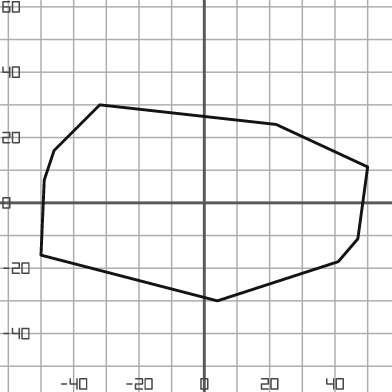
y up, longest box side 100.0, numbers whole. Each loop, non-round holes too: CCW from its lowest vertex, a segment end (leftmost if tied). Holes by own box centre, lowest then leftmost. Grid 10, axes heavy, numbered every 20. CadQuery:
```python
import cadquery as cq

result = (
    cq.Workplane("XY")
    .moveTo(4.0, -30.0)
    .lineTo(41.0, -18.0)
    .lineTo(47.0, -11.0)
    .lineTo(50.0, 11.0)
    .lineTo(22.0, 24.0)
    .lineTo(-32.0, 30.0)
    .lineTo(-46.0, 16.0)
    .lineTo(-49.0, 7.0)
    .lineTo(-50.0, -16.0)
    .close()
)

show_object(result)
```